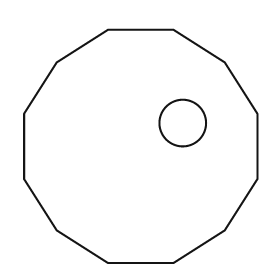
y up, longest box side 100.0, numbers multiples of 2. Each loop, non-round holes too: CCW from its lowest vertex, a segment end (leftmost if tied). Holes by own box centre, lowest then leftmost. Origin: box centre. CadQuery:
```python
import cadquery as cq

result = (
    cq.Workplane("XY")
    .moveTo(-14.0, -50.0)
    .lineTo(14.0, -50.0)
    .lineTo(36.0, -36.0)
    .lineTo(50.0, -14.0)
    .lineTo(50.0, 14.0)
    .lineTo(36.0, 36.0)
    .lineTo(14.0, 50.0)
    .lineTo(-14.0, 50.0)
    .lineTo(-36.0, 36.0)
    .lineTo(-50.0, 14.0)
    .lineTo(-50.0, -14.0)
    .lineTo(-36.0, -36.0)
    .close()
    .moveTo(18.0, 10.0)
    .circle(10.0)
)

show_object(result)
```